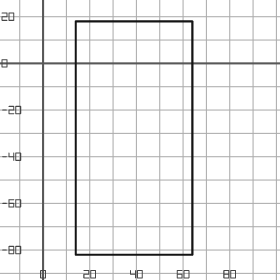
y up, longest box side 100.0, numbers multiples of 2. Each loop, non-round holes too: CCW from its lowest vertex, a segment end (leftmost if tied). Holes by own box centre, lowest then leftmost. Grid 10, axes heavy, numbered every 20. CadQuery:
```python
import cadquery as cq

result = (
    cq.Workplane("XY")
    .moveTo(14.0, -82.0)
    .lineTo(64.0, -82.0)
    .lineTo(64.0, 18.0)
    .lineTo(14.0, 18.0)
    .close()
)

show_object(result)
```